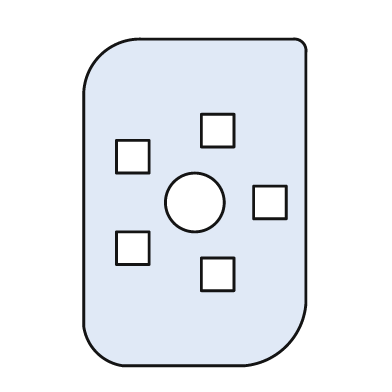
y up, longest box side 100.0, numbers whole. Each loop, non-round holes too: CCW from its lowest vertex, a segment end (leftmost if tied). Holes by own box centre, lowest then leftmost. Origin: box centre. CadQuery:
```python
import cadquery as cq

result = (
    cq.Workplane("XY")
    .moveTo(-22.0, -50.0)
    .lineTo(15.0, -50.0)
    .threePointArc((28.0, -44.0), (34.0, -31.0))
    .lineTo(34.0, 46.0)
    .threePointArc((33.0, 49.0), (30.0, 50.0))
    .lineTo(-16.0, 50.0)
    .threePointArc((-29.0, 45.0), (-34.0, 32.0))
    .lineTo(-34.0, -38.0)
    .threePointArc((-30.0, -46.0), (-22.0, -50.0))
    .close()
    .moveTo(2.0, -27.0)
    .lineTo(12.0, -27.0)
    .lineTo(12.0, -17.0)
    .lineTo(2.0, -17.0)
    .close()
    .moveTo(-24.0, -19.0)
    .lineTo(-14.0, -19.0)
    .lineTo(-14.0, -9.0)
    .lineTo(-24.0, -9.0)
    .close()
    .moveTo(0.0, 0.0)
    .circle(9.0)
    .moveTo(18.0, -5.0)
    .lineTo(28.0, -5.0)
    .lineTo(28.0, 5.0)
    .lineTo(18.0, 5.0)
    .close()
    .moveTo(-24.0, 9.0)
    .lineTo(-14.0, 9.0)
    .lineTo(-14.0, 19.0)
    .lineTo(-24.0, 19.0)
    .close()
    .moveTo(2.0, 17.0)
    .lineTo(12.0, 17.0)
    .lineTo(12.0, 27.0)
    .lineTo(2.0, 27.0)
    .close()
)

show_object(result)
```